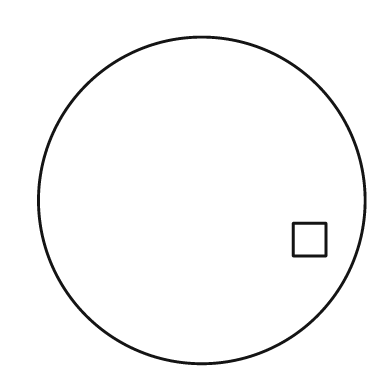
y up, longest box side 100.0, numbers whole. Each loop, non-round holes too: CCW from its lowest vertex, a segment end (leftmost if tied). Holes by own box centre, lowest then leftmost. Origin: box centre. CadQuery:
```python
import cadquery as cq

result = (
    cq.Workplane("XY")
    .moveTo(0.0, 0.0)
    .circle(50.0)
    .moveTo(28.0, -17.0)
    .lineTo(38.0, -17.0)
    .lineTo(38.0, -7.0)
    .lineTo(28.0, -7.0)
    .close()
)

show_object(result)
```